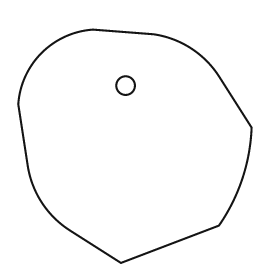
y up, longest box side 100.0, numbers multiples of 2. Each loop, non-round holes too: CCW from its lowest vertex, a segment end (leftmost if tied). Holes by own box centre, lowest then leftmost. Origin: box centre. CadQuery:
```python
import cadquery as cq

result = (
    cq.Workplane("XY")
    .moveTo(-6.0, -50.0)
    .lineTo(36.0, -34.0)
    .threePointArc((46.0, -14.0), (50.0, 8.0))
    .lineTo(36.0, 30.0)
    .threePointArc((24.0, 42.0), (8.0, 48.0))
    .lineTo(-18.0, 50.0)
    .threePointArc((-40.0, 40.0), (-50.0, 18.0))
    .lineTo(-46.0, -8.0)
    .threePointArc((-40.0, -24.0), (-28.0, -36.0))
    .close()
    .moveTo(-4.0, 26.0)
    .circle(4.0)
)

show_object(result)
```